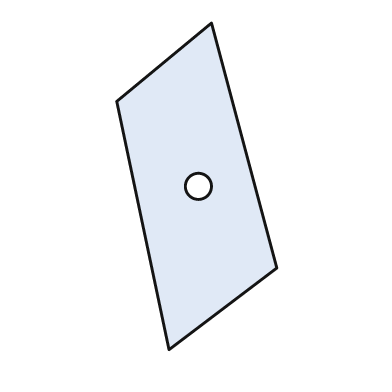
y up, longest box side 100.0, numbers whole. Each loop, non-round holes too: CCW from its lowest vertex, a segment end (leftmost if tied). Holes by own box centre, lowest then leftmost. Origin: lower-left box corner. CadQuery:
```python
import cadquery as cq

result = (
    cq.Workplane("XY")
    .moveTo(16.0, 0.0)
    .lineTo(49.0, 25.0)
    .lineTo(29.0, 100.0)
    .lineTo(0.0, 76.0)
    .close()
    .moveTo(25.0, 50.0)
    .circle(4.0)
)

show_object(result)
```